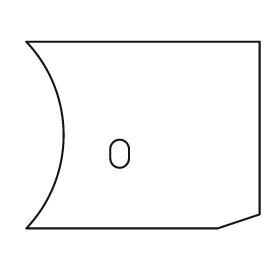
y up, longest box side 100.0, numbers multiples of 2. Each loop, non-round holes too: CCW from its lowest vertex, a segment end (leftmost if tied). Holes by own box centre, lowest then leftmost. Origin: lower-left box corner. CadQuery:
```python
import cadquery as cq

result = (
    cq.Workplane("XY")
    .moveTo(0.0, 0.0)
    .lineTo(82.0, 0.0)
    .lineTo(100.0, 6.0)
    .lineTo(100.0, 80.0)
    .lineTo(0.0, 80.0)
    .threePointArc((16.0, 40.0), (0.0, 0.0))
    .close()
    .moveTo(36.0, 30.0)
    .threePointArc((40.0, 26.0), (44.0, 30.0))
    .lineTo(44.0, 34.0)
    .threePointArc((40.0, 38.0), (36.0, 34.0))
    .close()
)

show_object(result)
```